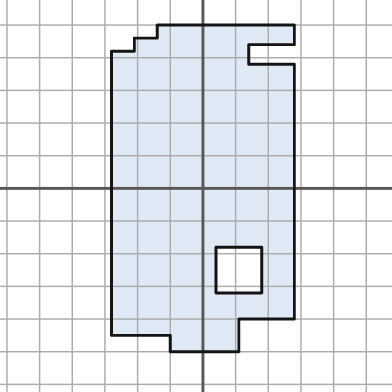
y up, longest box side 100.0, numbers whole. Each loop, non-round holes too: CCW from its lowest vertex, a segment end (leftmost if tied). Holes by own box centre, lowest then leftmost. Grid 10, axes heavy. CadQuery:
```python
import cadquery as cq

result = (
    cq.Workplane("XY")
    .moveTo(-10.0, -50.0)
    .lineTo(11.0, -50.0)
    .lineTo(11.0, -40.0)
    .lineTo(28.0, -40.0)
    .lineTo(28.0, 38.0)
    .lineTo(14.0, 38.0)
    .lineTo(14.0, 44.0)
    .lineTo(28.0, 44.0)
    .lineTo(28.0, 50.0)
    .lineTo(-14.0, 50.0)
    .lineTo(-14.0, 46.0)
    .lineTo(-21.0, 46.0)
    .lineTo(-21.0, 42.0)
    .lineTo(-28.0, 42.0)
    .lineTo(-28.0, -45.0)
    .lineTo(-10.0, -45.0)
    .close()
    .moveTo(4.0, -32.0)
    .lineTo(18.0, -32.0)
    .lineTo(18.0, -18.0)
    .lineTo(4.0, -18.0)
    .close()
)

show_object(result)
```